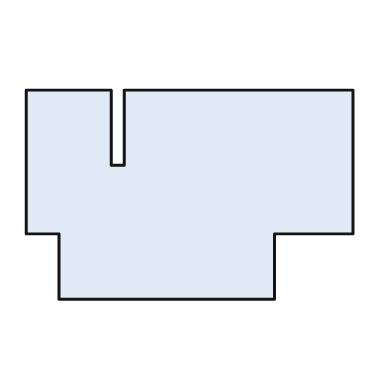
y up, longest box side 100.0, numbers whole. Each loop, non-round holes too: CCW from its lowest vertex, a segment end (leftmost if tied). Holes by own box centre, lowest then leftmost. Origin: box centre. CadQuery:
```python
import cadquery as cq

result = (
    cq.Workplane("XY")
    .moveTo(-40.0, -32.0)
    .lineTo(26.0, -32.0)
    .lineTo(26.0, -12.0)
    .lineTo(50.0, -12.0)
    .lineTo(50.0, 32.0)
    .lineTo(-20.0, 32.0)
    .lineTo(-20.0, 9.0)
    .lineTo(-24.0, 9.0)
    .lineTo(-24.0, 32.0)
    .lineTo(-50.0, 32.0)
    .lineTo(-50.0, -12.0)
    .lineTo(-40.0, -12.0)
    .close()
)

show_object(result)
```